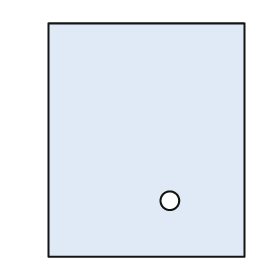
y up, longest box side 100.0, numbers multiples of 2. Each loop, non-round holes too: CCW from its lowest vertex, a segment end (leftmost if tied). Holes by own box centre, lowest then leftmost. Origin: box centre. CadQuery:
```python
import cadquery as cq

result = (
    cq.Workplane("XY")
    .moveTo(-42.0, -50.0)
    .lineTo(42.0, -50.0)
    .lineTo(42.0, 50.0)
    .lineTo(-42.0, 50.0)
    .close()
    .moveTo(10.0, -26.0)
    .circle(4.0)
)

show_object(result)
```